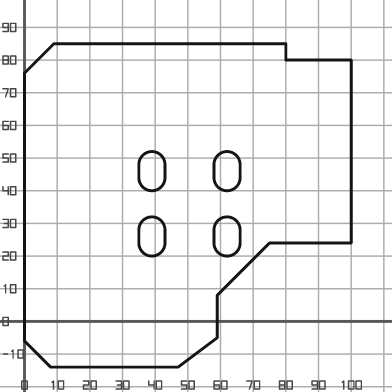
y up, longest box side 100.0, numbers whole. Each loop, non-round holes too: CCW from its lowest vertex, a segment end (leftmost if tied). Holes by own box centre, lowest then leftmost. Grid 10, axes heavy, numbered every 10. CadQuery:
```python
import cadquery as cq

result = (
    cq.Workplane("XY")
    .moveTo(8.0, -14.0)
    .lineTo(47.0, -14.0)
    .lineTo(59.0, -5.0)
    .lineTo(59.0, 8.0)
    .lineTo(75.0, 24.0)
    .lineTo(100.0, 24.0)
    .lineTo(100.0, 80.0)
    .lineTo(80.0, 80.0)
    .lineTo(80.0, 85.0)
    .lineTo(9.0, 85.0)
    .lineTo(0.0, 76.0)
    .lineTo(0.0, -6.0)
    .close()
    .moveTo(35.0, 24.0)
    .threePointArc((39.0, 20.0), (43.0, 24.0))
    .lineTo(43.0, 28.0)
    .threePointArc((39.0, 32.0), (35.0, 28.0))
    .close()
    .moveTo(58.0, 24.0)
    .threePointArc((62.0, 20.0), (66.0, 24.0))
    .lineTo(66.0, 28.0)
    .threePointArc((62.0, 32.0), (58.0, 28.0))
    .close()
    .moveTo(35.0, 44.0)
    .threePointArc((39.0, 40.0), (43.0, 44.0))
    .lineTo(43.0, 48.0)
    .threePointArc((39.0, 52.0), (35.0, 48.0))
    .close()
    .moveTo(58.0, 44.0)
    .threePointArc((62.0, 40.0), (66.0, 44.0))
    .lineTo(66.0, 48.0)
    .threePointArc((62.0, 52.0), (58.0, 48.0))
    .close()
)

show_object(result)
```